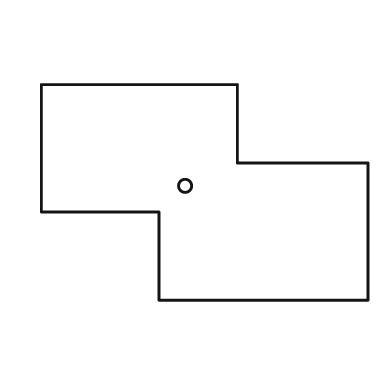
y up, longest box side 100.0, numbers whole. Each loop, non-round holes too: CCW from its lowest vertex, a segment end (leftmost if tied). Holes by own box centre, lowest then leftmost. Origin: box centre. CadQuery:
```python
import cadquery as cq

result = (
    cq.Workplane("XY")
    .moveTo(-14.0, -33.0)
    .lineTo(50.0, -33.0)
    .lineTo(50.0, 9.0)
    .lineTo(10.0, 9.0)
    .lineTo(10.0, 33.0)
    .lineTo(-50.0, 33.0)
    .lineTo(-50.0, -6.0)
    .lineTo(-14.0, -6.0)
    .close()
    .moveTo(-6.0, 2.0)
    .circle(2.0)
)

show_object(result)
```